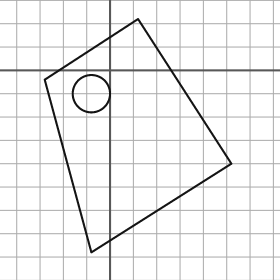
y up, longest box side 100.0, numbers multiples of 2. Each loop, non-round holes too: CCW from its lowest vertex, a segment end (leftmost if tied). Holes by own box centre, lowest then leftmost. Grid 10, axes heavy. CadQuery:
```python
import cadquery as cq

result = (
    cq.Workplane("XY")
    .moveTo(-8.0, -78.0)
    .lineTo(52.0, -40.0)
    .lineTo(12.0, 22.0)
    .lineTo(-28.0, -4.0)
    .close()
    .moveTo(-8.0, -10.0)
    .circle(8.0)
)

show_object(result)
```